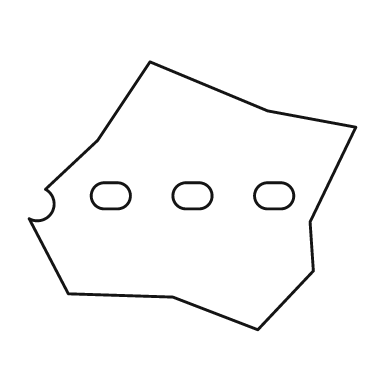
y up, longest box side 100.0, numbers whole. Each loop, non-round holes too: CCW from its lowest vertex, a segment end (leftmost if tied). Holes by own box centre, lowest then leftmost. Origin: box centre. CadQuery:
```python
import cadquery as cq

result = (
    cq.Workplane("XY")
    .moveTo(20.0, -41.0)
    .lineTo(37.0, -23.0)
    .lineTo(36.0, -8.0)
    .lineTo(50.0, 21.0)
    .lineTo(23.0, 26.0)
    .lineTo(-13.0, 41.0)
    .lineTo(-29.0, 17.0)
    .lineTo(-45.0, 2.0)
    .threePointArc((-43.0, -5.0), (-50.0, -7.0))
    .lineTo(-38.0, -30.0)
    .lineTo(-6.0, -31.0)
    .close()
    .moveTo(-27.0, -4.0)
    .lineTo(-23.0, -4.0)
    .threePointArc((-19.0, 0.0), (-23.0, 4.0))
    .lineTo(-27.0, 4.0)
    .threePointArc((-31.0, 0.0), (-27.0, -4.0))
    .close()
    .moveTo(-2.0, -4.0)
    .lineTo(2.0, -4.0)
    .threePointArc((6.0, 0.0), (2.0, 4.0))
    .lineTo(-2.0, 4.0)
    .threePointArc((-6.0, 0.0), (-2.0, -4.0))
    .close()
    .moveTo(23.0, -4.0)
    .lineTo(27.0, -4.0)
    .threePointArc((31.0, 0.0), (27.0, 4.0))
    .lineTo(23.0, 4.0)
    .threePointArc((19.0, 0.0), (23.0, -4.0))
    .close()
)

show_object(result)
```